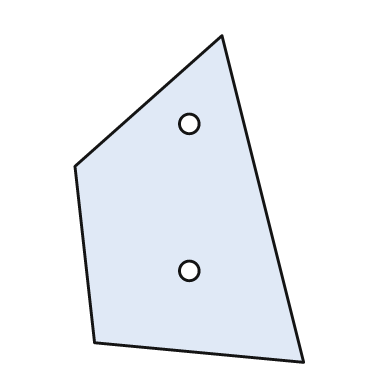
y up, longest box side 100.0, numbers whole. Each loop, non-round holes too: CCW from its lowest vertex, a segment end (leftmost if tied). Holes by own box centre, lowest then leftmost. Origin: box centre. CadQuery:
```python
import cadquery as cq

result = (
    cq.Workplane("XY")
    .moveTo(35.0, -50.0)
    .lineTo(10.0, 50.0)
    .lineTo(-35.0, 10.0)
    .lineTo(-29.0, -44.0)
    .close()
    .moveTo(0.0, -22.0)
    .circle(3.0)
    .moveTo(0.0, 23.0)
    .circle(3.0)
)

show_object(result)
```